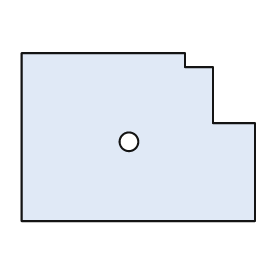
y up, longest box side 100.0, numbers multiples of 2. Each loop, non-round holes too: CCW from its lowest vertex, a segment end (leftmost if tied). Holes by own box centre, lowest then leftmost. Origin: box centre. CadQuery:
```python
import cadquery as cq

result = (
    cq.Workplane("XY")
    .moveTo(-50.0, -36.0)
    .lineTo(50.0, -36.0)
    .lineTo(50.0, 6.0)
    .lineTo(32.0, 6.0)
    .lineTo(32.0, 30.0)
    .lineTo(20.0, 30.0)
    .lineTo(20.0, 36.0)
    .lineTo(-50.0, 36.0)
    .close()
    .moveTo(-4.0, -2.0)
    .circle(4.0)
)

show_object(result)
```